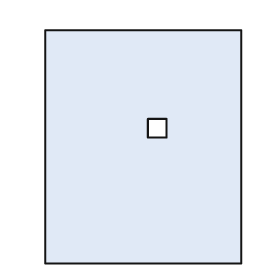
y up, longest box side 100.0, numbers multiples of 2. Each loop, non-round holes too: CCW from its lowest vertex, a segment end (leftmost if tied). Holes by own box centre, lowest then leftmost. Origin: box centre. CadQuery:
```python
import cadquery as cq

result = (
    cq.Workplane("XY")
    .moveTo(-42.0, -50.0)
    .lineTo(42.0, -50.0)
    .lineTo(42.0, 50.0)
    .lineTo(-42.0, 50.0)
    .close()
    .moveTo(2.0, 4.0)
    .lineTo(10.0, 4.0)
    .lineTo(10.0, 12.0)
    .lineTo(2.0, 12.0)
    .close()
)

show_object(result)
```